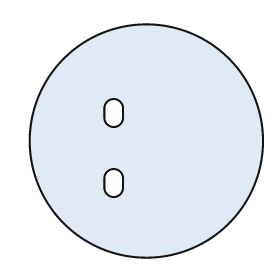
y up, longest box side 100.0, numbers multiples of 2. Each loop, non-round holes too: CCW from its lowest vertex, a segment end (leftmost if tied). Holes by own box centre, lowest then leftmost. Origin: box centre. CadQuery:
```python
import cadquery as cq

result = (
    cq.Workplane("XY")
    .moveTo(0.0, 0.0)
    .circle(50.0)
    .moveTo(-18.0, -20.0)
    .threePointArc((-14.0, -24.0), (-10.0, -20.0))
    .lineTo(-10.0, -16.0)
    .threePointArc((-14.0, -12.0), (-18.0, -16.0))
    .close()
    .moveTo(-18.0, 10.0)
    .threePointArc((-14.0, 6.0), (-10.0, 10.0))
    .lineTo(-10.0, 14.0)
    .threePointArc((-14.0, 18.0), (-18.0, 14.0))
    .close()
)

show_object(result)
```